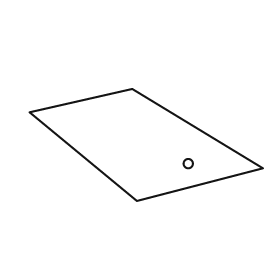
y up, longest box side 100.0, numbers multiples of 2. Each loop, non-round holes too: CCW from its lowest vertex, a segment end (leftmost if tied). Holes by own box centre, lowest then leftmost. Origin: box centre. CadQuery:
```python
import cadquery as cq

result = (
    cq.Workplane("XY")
    .moveTo(-4.0, -24.0)
    .lineTo(50.0, -10.0)
    .lineTo(-6.0, 24.0)
    .lineTo(-50.0, 14.0)
    .close()
    .moveTo(18.0, -8.0)
    .circle(2.0)
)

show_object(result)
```